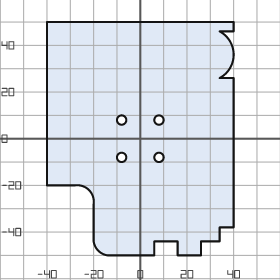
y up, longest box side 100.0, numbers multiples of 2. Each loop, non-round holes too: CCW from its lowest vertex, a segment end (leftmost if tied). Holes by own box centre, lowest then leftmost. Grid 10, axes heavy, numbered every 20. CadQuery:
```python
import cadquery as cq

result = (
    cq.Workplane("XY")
    .moveTo(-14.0, -50.0)
    .lineTo(6.0, -50.0)
    .lineTo(6.0, -44.0)
    .lineTo(16.0, -44.0)
    .lineTo(16.0, -50.0)
    .lineTo(26.0, -50.0)
    .lineTo(26.0, -44.0)
    .lineTo(34.0, -44.0)
    .lineTo(34.0, -38.0)
    .lineTo(40.0, -38.0)
    .lineTo(40.0, 26.0)
    .lineTo(34.0, 26.0)
    .threePointArc((40.0, 36.0), (34.0, 46.0))
    .lineTo(40.0, 46.0)
    .lineTo(40.0, 50.0)
    .lineTo(-40.0, 50.0)
    .lineTo(-40.0, -20.0)
    .lineTo(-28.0, -20.0)
    .threePointArc((-22.0, -22.0), (-20.0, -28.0))
    .lineTo(-20.0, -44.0)
    .threePointArc((-18.0, -48.0), (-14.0, -50.0))
    .close()
    .moveTo(-8.0, -8.0)
    .circle(2.0)
    .moveTo(8.0, -8.0)
    .circle(2.0)
    .moveTo(-8.0, 8.0)
    .circle(2.0)
    .moveTo(8.0, 8.0)
    .circle(2.0)
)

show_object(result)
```